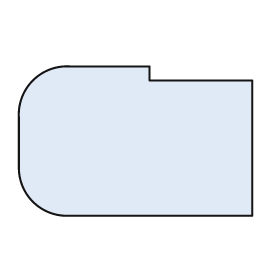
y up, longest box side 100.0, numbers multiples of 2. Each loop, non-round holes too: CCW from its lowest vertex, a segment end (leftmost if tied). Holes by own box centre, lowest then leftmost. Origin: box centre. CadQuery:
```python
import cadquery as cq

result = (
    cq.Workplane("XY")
    .moveTo(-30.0, -32.0)
    .lineTo(50.0, -32.0)
    .lineTo(50.0, 26.0)
    .lineTo(6.0, 26.0)
    .lineTo(6.0, 32.0)
    .lineTo(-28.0, 32.0)
    .threePointArc((-44.0, 26.0), (-50.0, 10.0))
    .lineTo(-50.0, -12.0)
    .threePointArc((-44.0, -26.0), (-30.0, -32.0))
    .close()
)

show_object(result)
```